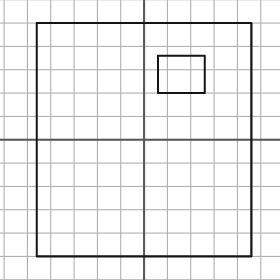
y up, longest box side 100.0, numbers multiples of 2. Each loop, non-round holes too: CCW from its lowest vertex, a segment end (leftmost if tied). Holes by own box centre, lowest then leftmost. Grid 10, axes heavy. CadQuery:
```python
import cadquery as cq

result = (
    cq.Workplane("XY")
    .moveTo(-46.0, -50.0)
    .lineTo(46.0, -50.0)
    .lineTo(46.0, 50.0)
    .lineTo(-46.0, 50.0)
    .close()
    .moveTo(6.0, 20.0)
    .lineTo(26.0, 20.0)
    .lineTo(26.0, 36.0)
    .lineTo(6.0, 36.0)
    .close()
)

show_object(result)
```